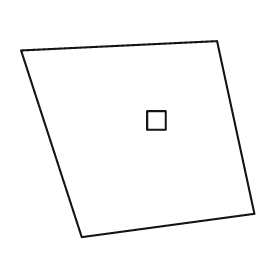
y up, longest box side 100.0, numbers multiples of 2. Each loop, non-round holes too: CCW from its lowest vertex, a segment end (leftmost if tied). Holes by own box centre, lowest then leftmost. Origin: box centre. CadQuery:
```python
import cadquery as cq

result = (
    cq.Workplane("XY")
    .moveTo(-24.0, -42.0)
    .lineTo(50.0, -32.0)
    .lineTo(34.0, 42.0)
    .lineTo(-50.0, 38.0)
    .close()
    .moveTo(4.0, 4.0)
    .lineTo(12.0, 4.0)
    .lineTo(12.0, 12.0)
    .lineTo(4.0, 12.0)
    .close()
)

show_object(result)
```